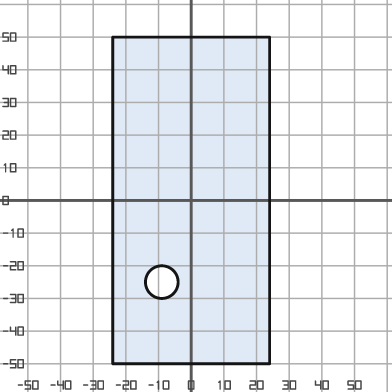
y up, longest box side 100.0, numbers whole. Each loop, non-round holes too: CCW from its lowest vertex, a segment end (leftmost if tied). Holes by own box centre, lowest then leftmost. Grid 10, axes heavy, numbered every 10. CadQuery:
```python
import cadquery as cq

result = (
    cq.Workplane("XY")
    .moveTo(-24.0, -50.0)
    .lineTo(24.0, -50.0)
    .lineTo(24.0, 50.0)
    .lineTo(-24.0, 50.0)
    .close()
    .moveTo(-9.0, -25.0)
    .circle(5.0)
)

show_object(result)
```